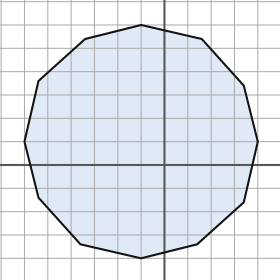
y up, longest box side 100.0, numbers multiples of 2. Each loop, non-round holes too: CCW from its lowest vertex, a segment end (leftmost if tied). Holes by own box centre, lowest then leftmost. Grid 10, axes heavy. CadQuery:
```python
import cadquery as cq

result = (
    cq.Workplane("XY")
    .moveTo(-10.0, -40.0)
    .lineTo(14.0, -34.0)
    .lineTo(34.0, -16.0)
    .lineTo(40.0, 10.0)
    .lineTo(34.0, 34.0)
    .lineTo(16.0, 54.0)
    .lineTo(-10.0, 60.0)
    .lineTo(-34.0, 54.0)
    .lineTo(-54.0, 36.0)
    .lineTo(-60.0, 10.0)
    .lineTo(-54.0, -14.0)
    .lineTo(-36.0, -34.0)
    .close()
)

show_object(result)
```